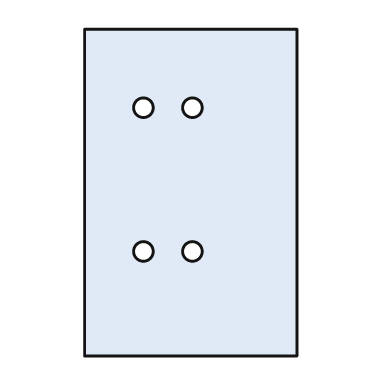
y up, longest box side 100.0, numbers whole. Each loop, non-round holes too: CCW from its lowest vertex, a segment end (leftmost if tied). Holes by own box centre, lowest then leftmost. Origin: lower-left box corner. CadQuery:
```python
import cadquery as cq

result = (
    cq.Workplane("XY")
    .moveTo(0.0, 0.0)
    .lineTo(65.0, 0.0)
    .lineTo(65.0, 100.0)
    .lineTo(0.0, 100.0)
    .close()
    .moveTo(18.0, 32.0)
    .circle(3.0)
    .moveTo(33.0, 32.0)
    .circle(3.0)
    .moveTo(18.0, 76.0)
    .circle(3.0)
    .moveTo(33.0, 76.0)
    .circle(3.0)
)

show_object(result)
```